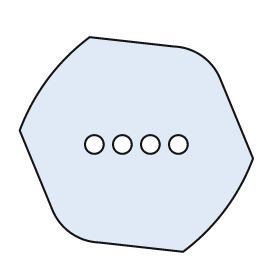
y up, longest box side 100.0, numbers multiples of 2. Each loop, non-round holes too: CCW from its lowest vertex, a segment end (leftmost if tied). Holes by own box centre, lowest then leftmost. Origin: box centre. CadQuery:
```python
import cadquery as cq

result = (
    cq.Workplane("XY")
    .moveTo(20.0, -46.0)
    .threePointArc((38.0, -28.0), (50.0, -6.0))
    .lineTo(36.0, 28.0)
    .threePointArc((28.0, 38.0), (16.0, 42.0))
    .lineTo(-20.0, 46.0)
    .threePointArc((-38.0, 28.0), (-50.0, 6.0))
    .lineTo(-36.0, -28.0)
    .threePointArc((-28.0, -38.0), (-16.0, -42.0))
    .close()
    .moveTo(-18.0, 0.0)
    .circle(4.0)
    .moveTo(-6.0, 0.0)
    .circle(4.0)
    .moveTo(6.0, 0.0)
    .circle(4.0)
    .moveTo(18.0, 0.0)
    .circle(4.0)
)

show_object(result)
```